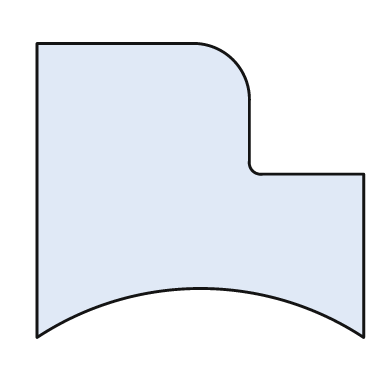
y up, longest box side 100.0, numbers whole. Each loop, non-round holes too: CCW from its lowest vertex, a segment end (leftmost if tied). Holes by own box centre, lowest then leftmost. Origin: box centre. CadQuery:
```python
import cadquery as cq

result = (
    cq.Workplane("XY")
    .moveTo(-50.0, -45.0)
    .threePointArc((0.0, -30.0), (50.0, -45.0))
    .lineTo(50.0, 5.0)
    .lineTo(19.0, 5.0)
    .threePointArc((16.0, 6.0), (15.0, 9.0))
    .lineTo(15.0, 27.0)
    .threePointArc((10.0, 40.0), (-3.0, 45.0))
    .lineTo(-50.0, 45.0)
    .close()
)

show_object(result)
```